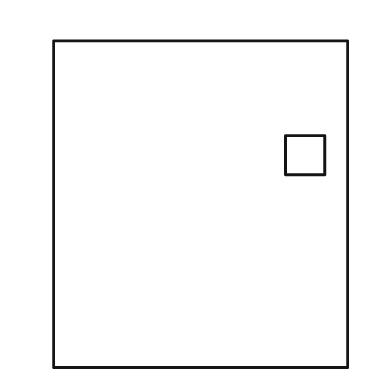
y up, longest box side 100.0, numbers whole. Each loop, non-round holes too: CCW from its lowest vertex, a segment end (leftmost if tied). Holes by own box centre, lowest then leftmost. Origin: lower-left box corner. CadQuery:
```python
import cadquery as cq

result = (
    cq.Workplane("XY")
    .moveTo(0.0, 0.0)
    .lineTo(90.0, 0.0)
    .lineTo(90.0, 100.0)
    .lineTo(0.0, 100.0)
    .close()
    .moveTo(71.0, 59.0)
    .lineTo(83.0, 59.0)
    .lineTo(83.0, 71.0)
    .lineTo(71.0, 71.0)
    .close()
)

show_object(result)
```